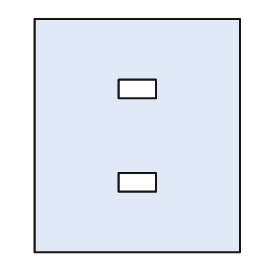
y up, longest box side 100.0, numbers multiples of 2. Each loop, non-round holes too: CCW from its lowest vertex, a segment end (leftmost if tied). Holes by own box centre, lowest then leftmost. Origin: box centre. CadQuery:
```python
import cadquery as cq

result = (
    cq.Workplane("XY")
    .moveTo(-44.0, -50.0)
    .lineTo(44.0, -50.0)
    .lineTo(44.0, 50.0)
    .lineTo(-44.0, 50.0)
    .close()
    .moveTo(-8.0, -24.0)
    .lineTo(8.0, -24.0)
    .lineTo(8.0, -16.0)
    .lineTo(-8.0, -16.0)
    .close()
    .moveTo(-8.0, 16.0)
    .lineTo(8.0, 16.0)
    .lineTo(8.0, 24.0)
    .lineTo(-8.0, 24.0)
    .close()
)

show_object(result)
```